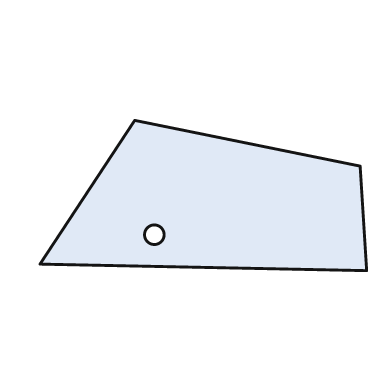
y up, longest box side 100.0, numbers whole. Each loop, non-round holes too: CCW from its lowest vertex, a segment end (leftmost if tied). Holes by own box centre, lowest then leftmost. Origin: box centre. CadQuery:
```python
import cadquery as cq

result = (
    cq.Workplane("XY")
    .moveTo(50.0, -23.0)
    .lineTo(48.0, 9.0)
    .lineTo(-21.0, 23.0)
    .lineTo(-50.0, -21.0)
    .close()
    .moveTo(-15.0, -12.0)
    .circle(3.0)
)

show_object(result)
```